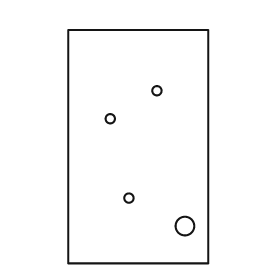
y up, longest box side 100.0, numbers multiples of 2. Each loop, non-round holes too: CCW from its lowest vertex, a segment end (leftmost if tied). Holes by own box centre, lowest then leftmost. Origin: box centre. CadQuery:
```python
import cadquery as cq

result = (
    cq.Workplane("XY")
    .moveTo(-30.0, -50.0)
    .lineTo(30.0, -50.0)
    .lineTo(30.0, 50.0)
    .lineTo(-30.0, 50.0)
    .close()
    .moveTo(20.0, -34.0)
    .circle(4.0)
    .moveTo(-4.0, -22.0)
    .circle(2.0)
    .moveTo(-12.0, 12.0)
    .circle(2.0)
    .moveTo(8.0, 24.0)
    .circle(2.0)
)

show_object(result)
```